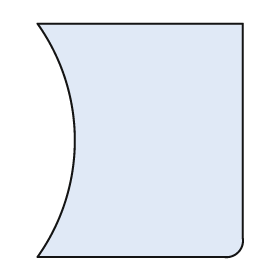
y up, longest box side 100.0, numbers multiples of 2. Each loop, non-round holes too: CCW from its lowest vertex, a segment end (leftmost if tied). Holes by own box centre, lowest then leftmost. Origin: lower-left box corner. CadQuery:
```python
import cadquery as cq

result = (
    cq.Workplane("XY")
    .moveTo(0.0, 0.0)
    .lineTo(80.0, 0.0)
    .threePointArc((86.0, 2.0), (88.0, 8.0))
    .lineTo(88.0, 100.0)
    .lineTo(0.0, 100.0)
    .threePointArc((16.0, 50.0), (0.0, 0.0))
    .close()
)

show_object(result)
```